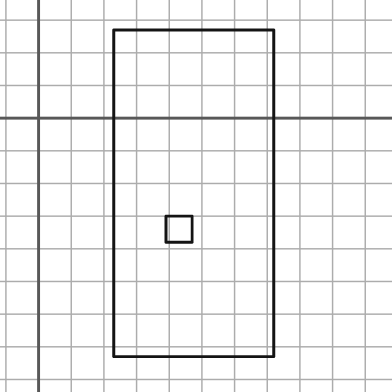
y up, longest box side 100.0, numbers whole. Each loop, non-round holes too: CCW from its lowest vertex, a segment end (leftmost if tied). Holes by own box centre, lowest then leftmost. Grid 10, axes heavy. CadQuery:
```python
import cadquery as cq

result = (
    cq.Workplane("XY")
    .moveTo(23.0, -73.0)
    .lineTo(72.0, -73.0)
    .lineTo(72.0, 27.0)
    .lineTo(23.0, 27.0)
    .close()
    .moveTo(39.0, -38.0)
    .lineTo(47.0, -38.0)
    .lineTo(47.0, -30.0)
    .lineTo(39.0, -30.0)
    .close()
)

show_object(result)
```